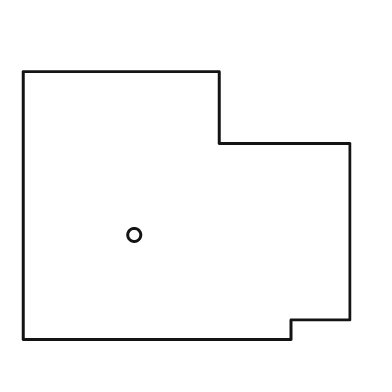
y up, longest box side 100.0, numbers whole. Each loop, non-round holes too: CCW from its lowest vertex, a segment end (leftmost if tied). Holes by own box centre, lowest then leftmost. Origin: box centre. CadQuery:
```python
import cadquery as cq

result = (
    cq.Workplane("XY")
    .moveTo(-50.0, -41.0)
    .lineTo(32.0, -41.0)
    .lineTo(32.0, -35.0)
    .lineTo(50.0, -35.0)
    .lineTo(50.0, 19.0)
    .lineTo(10.0, 19.0)
    .lineTo(10.0, 41.0)
    .lineTo(-50.0, 41.0)
    .close()
    .moveTo(-16.0, -9.0)
    .circle(2.0)
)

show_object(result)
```